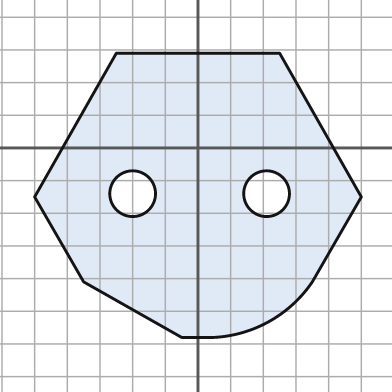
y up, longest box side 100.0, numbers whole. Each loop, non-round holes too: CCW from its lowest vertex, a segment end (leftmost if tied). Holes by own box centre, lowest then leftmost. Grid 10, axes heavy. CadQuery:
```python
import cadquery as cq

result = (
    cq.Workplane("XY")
    .moveTo(-5.0, -58.0)
    .lineTo(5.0, -58.0)
    .threePointArc((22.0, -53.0), (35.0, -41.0))
    .lineTo(50.0, -15.0)
    .lineTo(25.0, 29.0)
    .lineTo(-25.0, 29.0)
    .lineTo(-50.0, -15.0)
    .lineTo(-35.0, -41.0)
    .close()
    .moveTo(-20.0, -14.0)
    .circle(7.0)
    .moveTo(21.0, -14.0)
    .circle(7.0)
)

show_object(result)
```